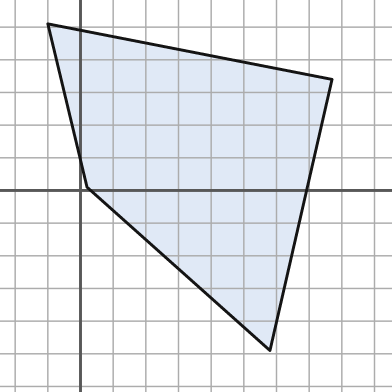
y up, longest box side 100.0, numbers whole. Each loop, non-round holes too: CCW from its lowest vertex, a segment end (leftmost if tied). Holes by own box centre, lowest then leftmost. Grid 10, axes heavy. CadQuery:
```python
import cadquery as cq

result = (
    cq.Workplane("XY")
    .moveTo(58.0, -49.0)
    .lineTo(77.0, 34.0)
    .lineTo(-10.0, 51.0)
    .lineTo(2.0, 1.0)
    .close()
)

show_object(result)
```